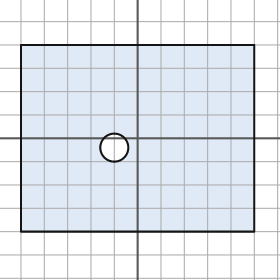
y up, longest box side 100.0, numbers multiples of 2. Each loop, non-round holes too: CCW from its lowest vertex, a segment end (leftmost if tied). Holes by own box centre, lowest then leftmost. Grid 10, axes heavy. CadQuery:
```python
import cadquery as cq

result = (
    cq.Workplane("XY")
    .moveTo(-50.0, -40.0)
    .lineTo(50.0, -40.0)
    .lineTo(50.0, 40.0)
    .lineTo(-50.0, 40.0)
    .close()
    .moveTo(-10.0, -4.0)
    .circle(6.0)
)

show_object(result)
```